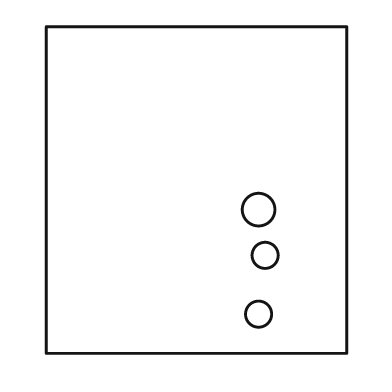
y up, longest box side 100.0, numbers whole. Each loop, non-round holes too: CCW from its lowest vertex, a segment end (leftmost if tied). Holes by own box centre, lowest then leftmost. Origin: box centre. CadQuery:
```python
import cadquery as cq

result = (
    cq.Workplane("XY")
    .moveTo(-46.0, -50.0)
    .lineTo(46.0, -50.0)
    .lineTo(46.0, 50.0)
    .lineTo(-46.0, 50.0)
    .close()
    .moveTo(19.0, -38.0)
    .circle(4.0)
    .moveTo(21.0, -20.0)
    .circle(4.0)
    .moveTo(19.0, -6.0)
    .circle(5.0)
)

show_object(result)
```